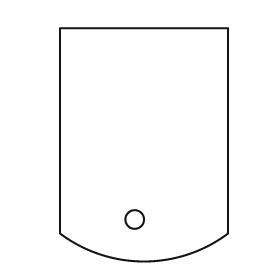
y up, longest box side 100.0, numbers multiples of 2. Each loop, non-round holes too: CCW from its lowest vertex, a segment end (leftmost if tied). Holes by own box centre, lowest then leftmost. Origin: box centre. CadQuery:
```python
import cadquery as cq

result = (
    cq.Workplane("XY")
    .moveTo(-36.0, -38.0)
    .threePointArc((0.0, -50.0), (36.0, -38.0))
    .lineTo(36.0, 50.0)
    .lineTo(-36.0, 50.0)
    .close()
    .moveTo(-4.0, -32.0)
    .circle(4.0)
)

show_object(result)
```